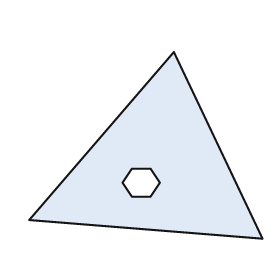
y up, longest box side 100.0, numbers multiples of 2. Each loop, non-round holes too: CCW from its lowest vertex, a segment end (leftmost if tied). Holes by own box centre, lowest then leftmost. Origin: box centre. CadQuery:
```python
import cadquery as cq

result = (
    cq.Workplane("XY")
    .moveTo(50.0, -40.0)
    .lineTo(12.0, 40.0)
    .lineTo(-50.0, -32.0)
    .close()
    .moveTo(-6.0, -22.0)
    .lineTo(2.0, -22.0)
    .lineTo(6.0, -16.0)
    .lineTo(2.0, -10.0)
    .lineTo(-6.0, -10.0)
    .lineTo(-10.0, -16.0)
    .close()
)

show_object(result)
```